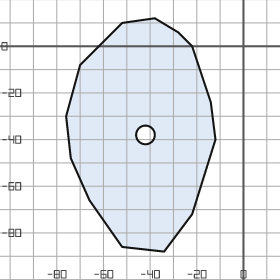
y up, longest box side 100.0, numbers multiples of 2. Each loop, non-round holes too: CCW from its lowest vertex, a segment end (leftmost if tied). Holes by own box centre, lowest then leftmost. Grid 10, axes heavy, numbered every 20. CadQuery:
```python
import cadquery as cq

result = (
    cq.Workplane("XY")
    .moveTo(-34.0, -88.0)
    .lineTo(-22.0, -72.0)
    .lineTo(-12.0, -40.0)
    .lineTo(-14.0, -24.0)
    .lineTo(-22.0, 0.0)
    .lineTo(-28.0, 6.0)
    .lineTo(-38.0, 12.0)
    .lineTo(-52.0, 10.0)
    .lineTo(-70.0, -8.0)
    .lineTo(-76.0, -30.0)
    .lineTo(-74.0, -48.0)
    .lineTo(-66.0, -66.0)
    .lineTo(-52.0, -86.0)
    .close()
    .moveTo(-42.0, -38.0)
    .circle(4.0)
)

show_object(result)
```